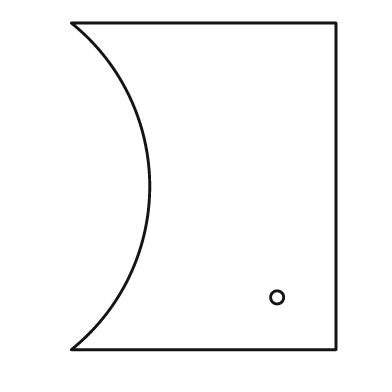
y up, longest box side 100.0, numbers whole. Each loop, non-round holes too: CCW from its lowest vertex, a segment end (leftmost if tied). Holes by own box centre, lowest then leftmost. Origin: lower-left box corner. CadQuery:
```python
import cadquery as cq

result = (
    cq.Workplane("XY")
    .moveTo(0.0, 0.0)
    .lineTo(81.0, 0.0)
    .lineTo(81.0, 100.0)
    .lineTo(0.0, 100.0)
    .threePointArc((24.0, 50.0), (0.0, 0.0))
    .close()
    .moveTo(63.0, 16.0)
    .circle(2.0)
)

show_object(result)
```